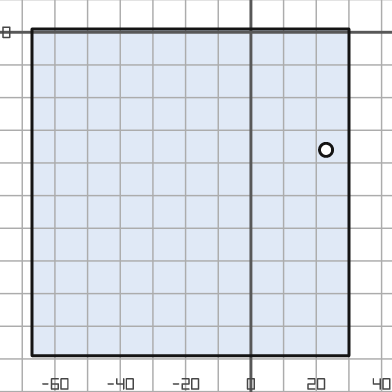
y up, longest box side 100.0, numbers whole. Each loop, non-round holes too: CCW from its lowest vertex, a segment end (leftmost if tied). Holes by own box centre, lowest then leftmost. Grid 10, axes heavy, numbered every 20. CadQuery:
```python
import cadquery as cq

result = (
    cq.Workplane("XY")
    .moveTo(-67.0, -99.0)
    .lineTo(30.0, -99.0)
    .lineTo(30.0, 1.0)
    .lineTo(-67.0, 1.0)
    .close()
    .moveTo(23.0, -36.0)
    .circle(2.0)
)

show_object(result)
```